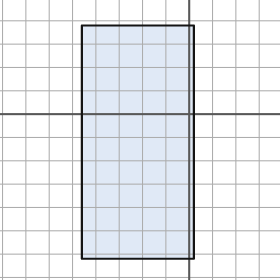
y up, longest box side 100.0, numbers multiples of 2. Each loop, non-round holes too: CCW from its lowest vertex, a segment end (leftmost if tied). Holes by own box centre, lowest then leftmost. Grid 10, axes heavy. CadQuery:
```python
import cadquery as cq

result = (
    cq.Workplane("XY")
    .moveTo(-46.0, -62.0)
    .lineTo(2.0, -62.0)
    .lineTo(2.0, 38.0)
    .lineTo(-46.0, 38.0)
    .close()
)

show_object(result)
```